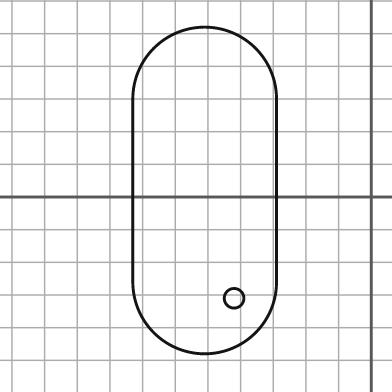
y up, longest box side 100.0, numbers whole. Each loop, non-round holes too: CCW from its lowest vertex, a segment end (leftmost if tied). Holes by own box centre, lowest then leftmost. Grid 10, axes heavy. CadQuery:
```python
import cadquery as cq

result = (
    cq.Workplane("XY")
    .moveTo(-73.0, -26.0)
    .threePointArc((-51.0, -48.0), (-29.0, -26.0))
    .lineTo(-29.0, 30.0)
    .threePointArc((-51.0, 52.0), (-73.0, 30.0))
    .close()
    .moveTo(-42.0, -31.0)
    .circle(3.0)
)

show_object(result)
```